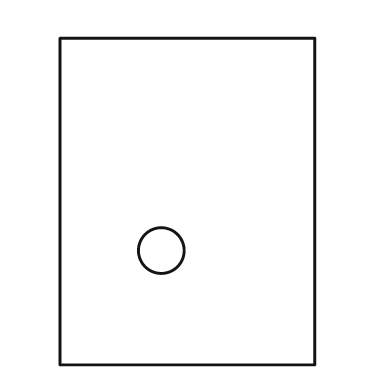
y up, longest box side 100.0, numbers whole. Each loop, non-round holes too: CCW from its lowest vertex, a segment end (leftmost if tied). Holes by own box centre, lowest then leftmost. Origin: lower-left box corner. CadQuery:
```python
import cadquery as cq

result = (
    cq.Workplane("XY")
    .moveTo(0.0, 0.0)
    .lineTo(78.0, 0.0)
    .lineTo(78.0, 100.0)
    .lineTo(0.0, 100.0)
    .close()
    .moveTo(31.0, 35.0)
    .circle(7.0)
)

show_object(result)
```